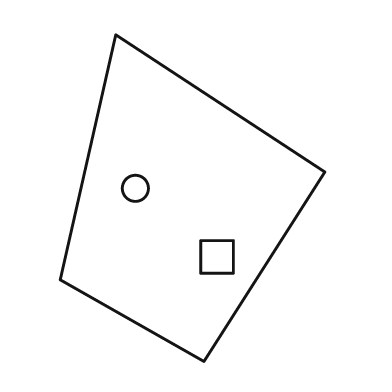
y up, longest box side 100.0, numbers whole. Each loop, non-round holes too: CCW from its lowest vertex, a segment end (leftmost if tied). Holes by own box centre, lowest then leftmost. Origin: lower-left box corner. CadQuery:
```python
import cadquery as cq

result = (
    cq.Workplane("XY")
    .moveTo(44.0, 0.0)
    .lineTo(81.0, 58.0)
    .lineTo(17.0, 100.0)
    .lineTo(0.0, 25.0)
    .close()
    .moveTo(43.0, 27.0)
    .lineTo(53.0, 27.0)
    .lineTo(53.0, 37.0)
    .lineTo(43.0, 37.0)
    .close()
    .moveTo(23.0, 53.0)
    .circle(4.0)
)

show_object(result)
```